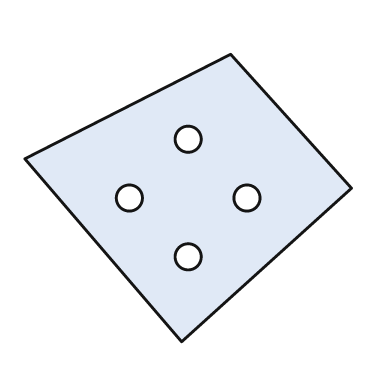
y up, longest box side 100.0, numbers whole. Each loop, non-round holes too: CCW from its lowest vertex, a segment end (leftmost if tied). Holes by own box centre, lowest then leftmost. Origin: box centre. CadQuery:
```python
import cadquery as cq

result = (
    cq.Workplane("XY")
    .moveTo(-2.0, -44.0)
    .lineTo(50.0, 3.0)
    .lineTo(13.0, 44.0)
    .lineTo(-50.0, 12.0)
    .close()
    .moveTo(0.0, -18.0)
    .circle(4.0)
    .moveTo(-18.0, 0.0)
    .circle(4.0)
    .moveTo(18.0, 0.0)
    .circle(4.0)
    .moveTo(0.0, 18.0)
    .circle(4.0)
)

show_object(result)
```